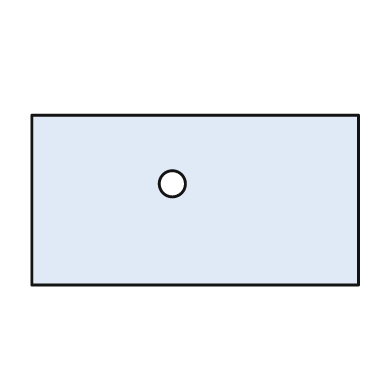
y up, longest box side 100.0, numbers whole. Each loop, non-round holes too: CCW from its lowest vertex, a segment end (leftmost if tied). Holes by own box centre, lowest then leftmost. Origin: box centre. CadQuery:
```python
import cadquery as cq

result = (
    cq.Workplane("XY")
    .moveTo(-50.0, -26.0)
    .lineTo(50.0, -26.0)
    .lineTo(50.0, 26.0)
    .lineTo(-50.0, 26.0)
    .close()
    .moveTo(-7.0, 5.0)
    .circle(4.0)
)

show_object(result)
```